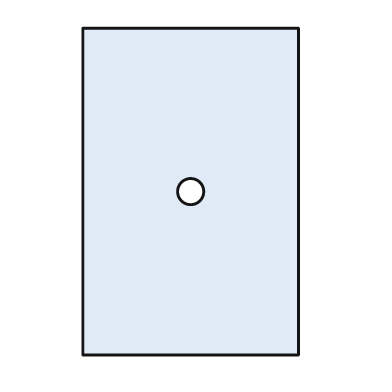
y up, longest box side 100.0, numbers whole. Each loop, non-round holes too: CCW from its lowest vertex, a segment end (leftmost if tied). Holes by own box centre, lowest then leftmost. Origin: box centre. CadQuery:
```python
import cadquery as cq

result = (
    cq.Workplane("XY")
    .moveTo(-33.0, -50.0)
    .lineTo(33.0, -50.0)
    .lineTo(33.0, 50.0)
    .lineTo(-33.0, 50.0)
    .close()
    .moveTo(0.0, 0.0)
    .circle(4.0)
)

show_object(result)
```